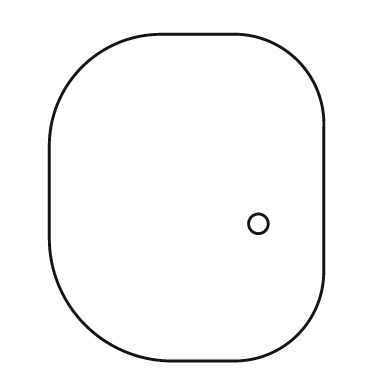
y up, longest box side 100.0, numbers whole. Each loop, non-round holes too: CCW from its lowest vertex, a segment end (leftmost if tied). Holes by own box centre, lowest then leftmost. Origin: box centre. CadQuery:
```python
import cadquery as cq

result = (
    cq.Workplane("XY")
    .moveTo(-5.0, -50.0)
    .lineTo(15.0, -50.0)
    .threePointArc((34.0, -42.0), (42.0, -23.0))
    .lineTo(42.0, 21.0)
    .threePointArc((34.0, 42.0), (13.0, 50.0))
    .lineTo(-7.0, 50.0)
    .threePointArc((-32.0, 40.0), (-42.0, 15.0))
    .lineTo(-42.0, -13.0)
    .threePointArc((-31.0, -39.0), (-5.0, -50.0))
    .close()
    .moveTo(22.0, -8.0)
    .circle(3.0)
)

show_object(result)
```